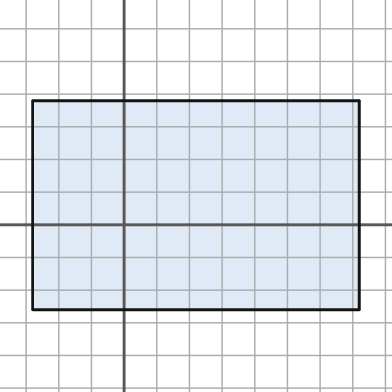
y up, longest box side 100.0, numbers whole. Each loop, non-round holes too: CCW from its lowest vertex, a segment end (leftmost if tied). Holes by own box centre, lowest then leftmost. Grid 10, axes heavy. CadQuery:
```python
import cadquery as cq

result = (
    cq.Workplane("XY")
    .moveTo(-28.0, -26.0)
    .lineTo(72.0, -26.0)
    .lineTo(72.0, 38.0)
    .lineTo(-28.0, 38.0)
    .close()
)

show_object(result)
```